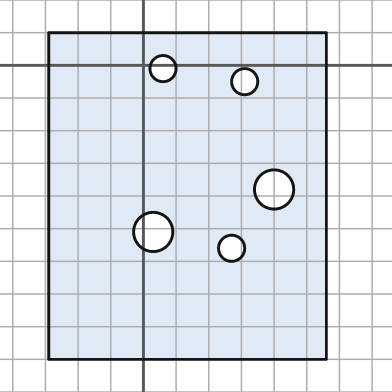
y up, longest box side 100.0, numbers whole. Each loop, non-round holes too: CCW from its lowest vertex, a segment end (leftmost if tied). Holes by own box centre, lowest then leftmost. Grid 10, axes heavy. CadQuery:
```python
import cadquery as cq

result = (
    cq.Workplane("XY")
    .moveTo(-29.0, -90.0)
    .lineTo(56.0, -90.0)
    .lineTo(56.0, 10.0)
    .lineTo(-29.0, 10.0)
    .close()
    .moveTo(27.0, -56.0)
    .circle(4.0)
    .moveTo(3.0, -51.0)
    .circle(6.0)
    .moveTo(40.0, -38.0)
    .circle(6.0)
    .moveTo(31.0, -5.0)
    .circle(4.0)
    .moveTo(6.0, -1.0)
    .circle(4.0)
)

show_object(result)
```